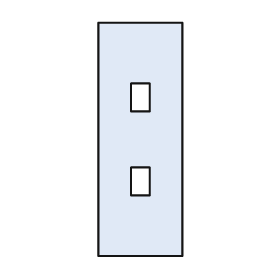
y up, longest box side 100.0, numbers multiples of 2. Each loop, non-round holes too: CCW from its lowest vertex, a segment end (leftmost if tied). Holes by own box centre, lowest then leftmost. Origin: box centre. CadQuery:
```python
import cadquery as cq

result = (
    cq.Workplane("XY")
    .moveTo(-18.0, -50.0)
    .lineTo(18.0, -50.0)
    .lineTo(18.0, 50.0)
    .lineTo(-18.0, 50.0)
    .close()
    .moveTo(-4.0, -24.0)
    .lineTo(4.0, -24.0)
    .lineTo(4.0, -12.0)
    .lineTo(-4.0, -12.0)
    .close()
    .moveTo(-4.0, 12.0)
    .lineTo(4.0, 12.0)
    .lineTo(4.0, 24.0)
    .lineTo(-4.0, 24.0)
    .close()
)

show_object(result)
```